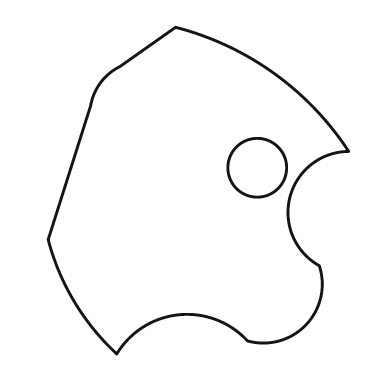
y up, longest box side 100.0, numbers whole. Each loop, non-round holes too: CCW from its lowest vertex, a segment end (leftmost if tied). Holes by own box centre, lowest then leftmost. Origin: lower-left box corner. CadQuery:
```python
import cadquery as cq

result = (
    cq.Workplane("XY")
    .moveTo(21.0, 0.0)
    .threePointArc((40.0, 12.0), (61.0, 4.0))
    .threePointArc((79.0, 9.0), (83.0, 27.0))
    .threePointArc((74.0, 48.0), (92.0, 62.0))
    .threePointArc((69.0, 86.0), (39.0, 100.0))
    .lineTo(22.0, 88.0)
    .threePointArc((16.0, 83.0), (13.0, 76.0))
    .lineTo(0.0, 35.0)
    .threePointArc((8.0, 16.0), (21.0, 0.0))
    .close()
    .moveTo(64.0, 57.0)
    .circle(9.0)
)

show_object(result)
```